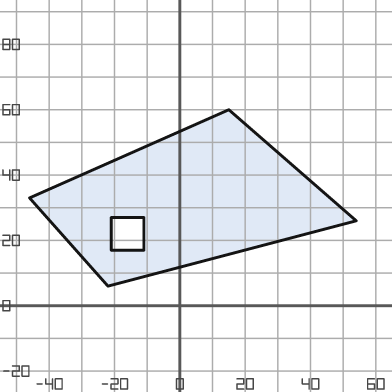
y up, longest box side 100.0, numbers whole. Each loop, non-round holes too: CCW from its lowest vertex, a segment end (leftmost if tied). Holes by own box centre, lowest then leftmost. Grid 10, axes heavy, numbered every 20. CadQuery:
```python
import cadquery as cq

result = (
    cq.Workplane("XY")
    .moveTo(-22.0, 6.0)
    .lineTo(54.0, 26.0)
    .lineTo(15.0, 60.0)
    .lineTo(-46.0, 33.0)
    .close()
    .moveTo(-21.0, 17.0)
    .lineTo(-11.0, 17.0)
    .lineTo(-11.0, 27.0)
    .lineTo(-21.0, 27.0)
    .close()
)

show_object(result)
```